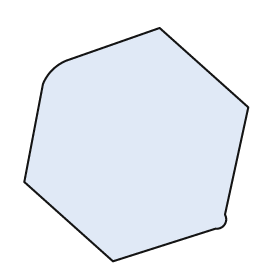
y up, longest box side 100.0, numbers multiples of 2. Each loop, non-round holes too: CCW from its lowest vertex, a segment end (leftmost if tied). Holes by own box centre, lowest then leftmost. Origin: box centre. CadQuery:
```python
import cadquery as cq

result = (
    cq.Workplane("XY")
    .moveTo(-10.0, -50.0)
    .lineTo(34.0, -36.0)
    .threePointArc((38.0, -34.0), (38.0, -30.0))
    .lineTo(48.0, 16.0)
    .lineTo(10.0, 50.0)
    .lineTo(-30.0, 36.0)
    .threePointArc((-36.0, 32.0), (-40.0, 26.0))
    .lineTo(-48.0, -16.0)
    .close()
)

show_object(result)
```